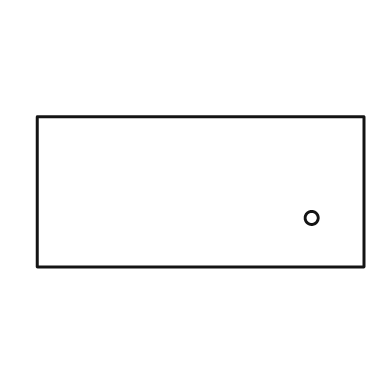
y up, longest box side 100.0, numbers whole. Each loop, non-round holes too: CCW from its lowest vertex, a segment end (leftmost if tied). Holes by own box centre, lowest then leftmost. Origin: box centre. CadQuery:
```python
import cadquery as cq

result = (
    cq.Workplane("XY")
    .moveTo(-50.0, -23.0)
    .lineTo(50.0, -23.0)
    .lineTo(50.0, 23.0)
    .lineTo(-50.0, 23.0)
    .close()
    .moveTo(34.0, -8.0)
    .circle(2.0)
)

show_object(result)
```